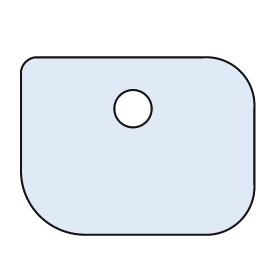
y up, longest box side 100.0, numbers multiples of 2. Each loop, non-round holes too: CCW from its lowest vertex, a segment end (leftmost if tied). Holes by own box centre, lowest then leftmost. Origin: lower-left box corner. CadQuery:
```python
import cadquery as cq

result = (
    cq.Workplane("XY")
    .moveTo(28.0, 0.0)
    .lineTo(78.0, 0.0)
    .threePointArc((94.0, 6.0), (100.0, 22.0))
    .lineTo(100.0, 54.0)
    .threePointArc((94.0, 70.0), (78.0, 76.0))
    .lineTo(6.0, 76.0)
    .threePointArc((2.0, 74.0), (0.0, 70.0))
    .lineTo(0.0, 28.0)
    .threePointArc((8.0, 8.0), (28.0, 0.0))
    .close()
    .moveTo(48.0, 54.0)
    .circle(8.0)
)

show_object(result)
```